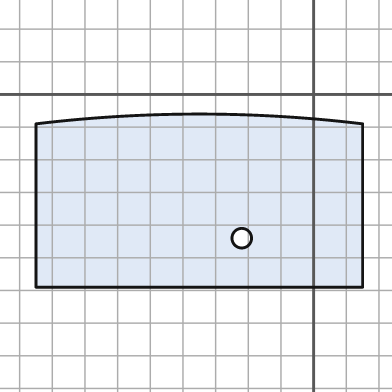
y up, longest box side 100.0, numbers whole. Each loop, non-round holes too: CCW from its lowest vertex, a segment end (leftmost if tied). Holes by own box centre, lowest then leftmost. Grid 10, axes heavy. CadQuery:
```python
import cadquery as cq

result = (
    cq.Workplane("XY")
    .moveTo(-85.0, -59.0)
    .lineTo(15.0, -59.0)
    .lineTo(15.0, -9.0)
    .threePointArc((-35.0, -6.0), (-85.0, -9.0))
    .close()
    .moveTo(-22.0, -44.0)
    .circle(3.0)
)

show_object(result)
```